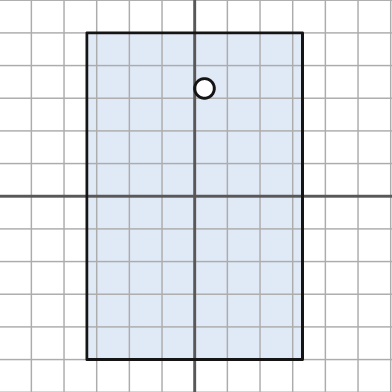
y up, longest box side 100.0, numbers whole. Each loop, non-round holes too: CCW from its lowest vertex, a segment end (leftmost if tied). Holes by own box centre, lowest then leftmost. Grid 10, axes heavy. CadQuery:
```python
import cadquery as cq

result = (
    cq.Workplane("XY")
    .moveTo(-33.0, -50.0)
    .lineTo(33.0, -50.0)
    .lineTo(33.0, 50.0)
    .lineTo(-33.0, 50.0)
    .close()
    .moveTo(3.0, 33.0)
    .circle(3.0)
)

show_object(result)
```